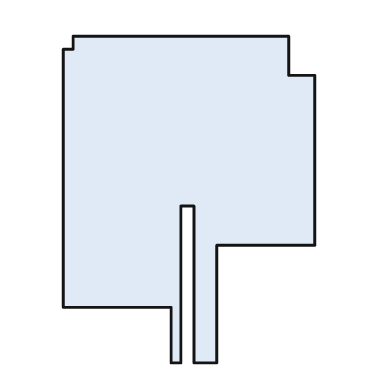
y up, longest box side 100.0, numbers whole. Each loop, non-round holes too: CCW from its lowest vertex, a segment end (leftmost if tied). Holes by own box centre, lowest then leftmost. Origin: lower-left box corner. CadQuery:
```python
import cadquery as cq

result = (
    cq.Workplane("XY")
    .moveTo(33.0, 0.0)
    .lineTo(36.0, 0.0)
    .lineTo(36.0, 48.0)
    .lineTo(40.0, 48.0)
    .lineTo(40.0, 0.0)
    .lineTo(47.0, 0.0)
    .lineTo(47.0, 36.0)
    .lineTo(77.0, 36.0)
    .lineTo(77.0, 88.0)
    .lineTo(69.0, 88.0)
    .lineTo(69.0, 100.0)
    .lineTo(3.0, 100.0)
    .lineTo(3.0, 96.0)
    .lineTo(0.0, 96.0)
    .lineTo(0.0, 17.0)
    .lineTo(33.0, 17.0)
    .close()
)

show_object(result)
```